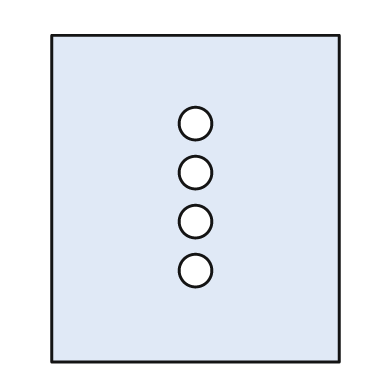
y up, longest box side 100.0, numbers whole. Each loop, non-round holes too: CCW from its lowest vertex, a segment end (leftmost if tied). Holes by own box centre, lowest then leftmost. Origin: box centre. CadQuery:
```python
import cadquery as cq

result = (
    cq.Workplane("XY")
    .moveTo(-44.0, -50.0)
    .lineTo(44.0, -50.0)
    .lineTo(44.0, 50.0)
    .lineTo(-44.0, 50.0)
    .close()
    .moveTo(0.0, -22.0)
    .circle(5.0)
    .moveTo(0.0, -7.0)
    .circle(5.0)
    .moveTo(0.0, 8.0)
    .circle(5.0)
    .moveTo(0.0, 23.0)
    .circle(5.0)
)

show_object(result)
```